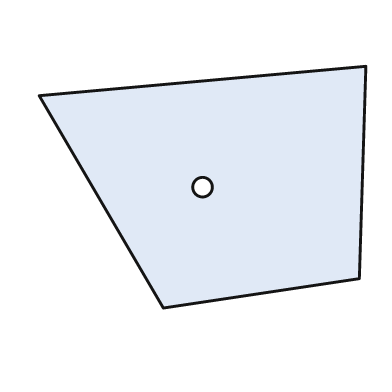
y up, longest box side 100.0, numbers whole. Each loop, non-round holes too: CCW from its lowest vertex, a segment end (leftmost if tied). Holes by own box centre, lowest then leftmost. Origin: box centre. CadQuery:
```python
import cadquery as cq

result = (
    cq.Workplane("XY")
    .moveTo(-12.0, -37.0)
    .lineTo(48.0, -28.0)
    .lineTo(50.0, 37.0)
    .lineTo(-50.0, 28.0)
    .close()
    .moveTo(0.0, 0.0)
    .circle(3.0)
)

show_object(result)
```